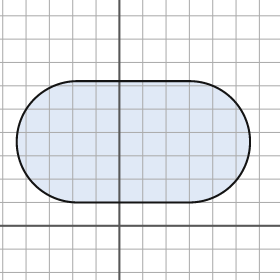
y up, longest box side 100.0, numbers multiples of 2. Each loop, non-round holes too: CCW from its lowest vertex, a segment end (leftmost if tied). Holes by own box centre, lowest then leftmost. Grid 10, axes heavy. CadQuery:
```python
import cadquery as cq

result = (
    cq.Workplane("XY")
    .moveTo(-18.0, 10.0)
    .lineTo(30.0, 10.0)
    .threePointArc((56.0, 36.0), (30.0, 62.0))
    .lineTo(-18.0, 62.0)
    .threePointArc((-44.0, 36.0), (-18.0, 10.0))
    .close()
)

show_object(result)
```